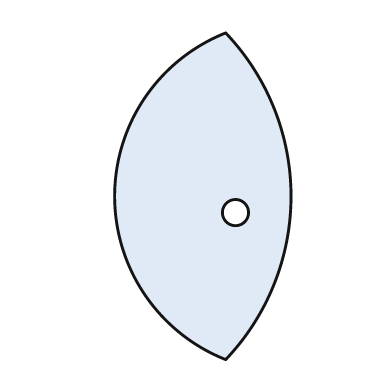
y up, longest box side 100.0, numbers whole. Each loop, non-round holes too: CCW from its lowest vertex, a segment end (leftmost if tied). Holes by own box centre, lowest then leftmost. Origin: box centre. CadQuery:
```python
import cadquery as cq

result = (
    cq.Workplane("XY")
    .moveTo(7.0, -50.0)
    .threePointArc((27.0, 0.0), (7.0, 50.0))
    .threePointArc((-27.0, 0.0), (7.0, -50.0))
    .close()
    .moveTo(10.0, -5.0)
    .circle(4.0)
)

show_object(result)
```